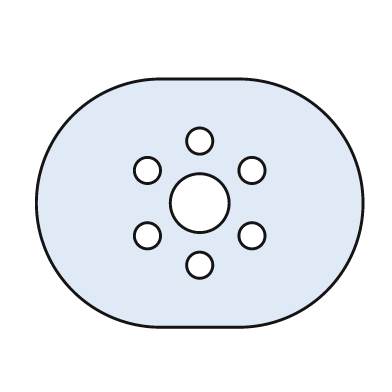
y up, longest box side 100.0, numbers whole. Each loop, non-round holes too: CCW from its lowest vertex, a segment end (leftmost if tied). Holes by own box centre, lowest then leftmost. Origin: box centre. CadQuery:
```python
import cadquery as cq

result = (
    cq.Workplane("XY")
    .moveTo(-12.0, -38.0)
    .lineTo(12.0, -38.0)
    .threePointArc((50.0, 0.0), (12.0, 38.0))
    .lineTo(-12.0, 38.0)
    .threePointArc((-50.0, 0.0), (-12.0, -38.0))
    .close()
    .moveTo(0.0, -19.0)
    .circle(4.0)
    .moveTo(-16.0, -10.0)
    .circle(4.0)
    .moveTo(16.0, -10.0)
    .circle(4.0)
    .moveTo(0.0, 0.0)
    .circle(9.0)
    .moveTo(-16.0, 10.0)
    .circle(4.0)
    .moveTo(16.0, 10.0)
    .circle(4.0)
    .moveTo(0.0, 19.0)
    .circle(4.0)
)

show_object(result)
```